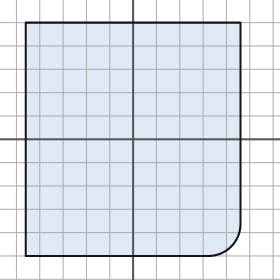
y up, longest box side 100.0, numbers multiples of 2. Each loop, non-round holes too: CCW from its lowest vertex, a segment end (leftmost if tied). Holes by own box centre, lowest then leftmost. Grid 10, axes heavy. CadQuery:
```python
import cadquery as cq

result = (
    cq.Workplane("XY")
    .moveTo(-46.0, -50.0)
    .lineTo(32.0, -50.0)
    .threePointArc((42.0, -46.0), (46.0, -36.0))
    .lineTo(46.0, 50.0)
    .lineTo(-46.0, 50.0)
    .close()
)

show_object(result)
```